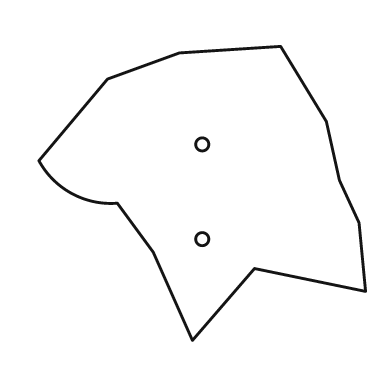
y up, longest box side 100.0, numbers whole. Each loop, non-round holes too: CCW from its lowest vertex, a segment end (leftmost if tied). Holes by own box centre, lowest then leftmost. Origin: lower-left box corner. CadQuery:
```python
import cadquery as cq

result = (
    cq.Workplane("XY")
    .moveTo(47.0, 0.0)
    .lineTo(66.0, 22.0)
    .lineTo(100.0, 15.0)
    .lineTo(98.0, 36.0)
    .lineTo(92.0, 49.0)
    .lineTo(88.0, 67.0)
    .lineTo(74.0, 90.0)
    .lineTo(43.0, 88.0)
    .lineTo(21.0, 80.0)
    .lineTo(0.0, 55.0)
    .threePointArc((10.0, 45.0), (24.0, 42.0))
    .lineTo(35.0, 27.0)
    .close()
    .moveTo(50.0, 31.0)
    .circle(2.0)
    .moveTo(50.0, 60.0)
    .circle(2.0)
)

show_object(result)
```